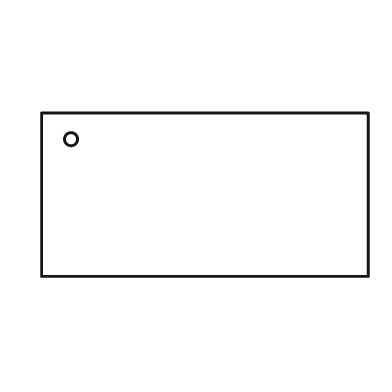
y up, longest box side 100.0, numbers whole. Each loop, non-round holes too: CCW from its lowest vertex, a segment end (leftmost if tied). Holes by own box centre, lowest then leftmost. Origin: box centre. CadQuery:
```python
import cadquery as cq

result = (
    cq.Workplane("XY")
    .moveTo(-50.0, -25.0)
    .lineTo(50.0, -25.0)
    .lineTo(50.0, 25.0)
    .lineTo(-50.0, 25.0)
    .close()
    .moveTo(-41.0, 17.0)
    .circle(2.0)
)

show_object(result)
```